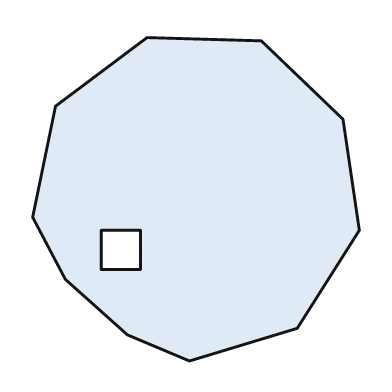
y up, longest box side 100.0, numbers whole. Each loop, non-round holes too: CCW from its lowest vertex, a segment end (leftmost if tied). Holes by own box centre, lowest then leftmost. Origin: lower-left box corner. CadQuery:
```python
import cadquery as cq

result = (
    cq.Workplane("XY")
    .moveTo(48.0, 0.0)
    .lineTo(81.0, 10.0)
    .lineTo(100.0, 40.0)
    .lineTo(95.0, 74.0)
    .lineTo(70.0, 98.0)
    .lineTo(35.0, 99.0)
    .lineTo(7.0, 78.0)
    .lineTo(0.0, 44.0)
    .lineTo(10.0, 25.0)
    .lineTo(29.0, 8.0)
    .close()
    .moveTo(21.0, 28.0)
    .lineTo(33.0, 28.0)
    .lineTo(33.0, 40.0)
    .lineTo(21.0, 40.0)
    .close()
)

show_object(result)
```